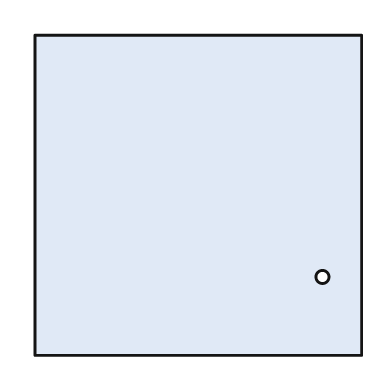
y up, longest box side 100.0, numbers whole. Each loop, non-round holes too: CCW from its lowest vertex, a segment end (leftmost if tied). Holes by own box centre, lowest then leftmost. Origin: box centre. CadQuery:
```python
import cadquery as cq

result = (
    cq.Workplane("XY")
    .moveTo(-50.0, -49.0)
    .lineTo(50.0, -49.0)
    .lineTo(50.0, 49.0)
    .lineTo(-50.0, 49.0)
    .close()
    .moveTo(38.0, -25.0)
    .circle(2.0)
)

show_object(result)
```